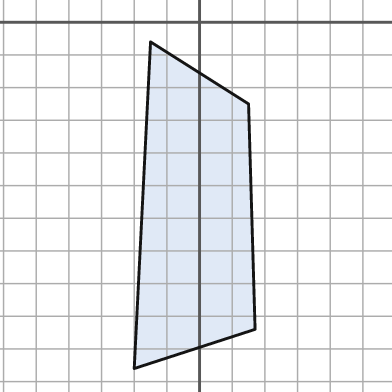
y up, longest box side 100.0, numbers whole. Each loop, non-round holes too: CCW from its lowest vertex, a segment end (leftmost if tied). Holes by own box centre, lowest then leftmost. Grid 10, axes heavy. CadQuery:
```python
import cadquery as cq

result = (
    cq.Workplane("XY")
    .moveTo(-20.0, -106.0)
    .lineTo(17.0, -94.0)
    .lineTo(15.0, -25.0)
    .lineTo(-15.0, -6.0)
    .close()
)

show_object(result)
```